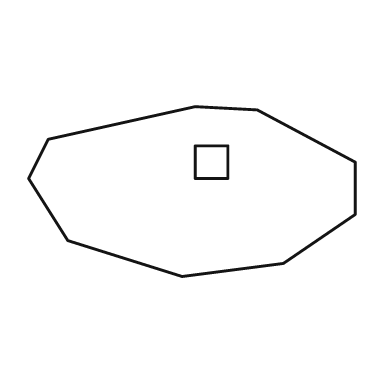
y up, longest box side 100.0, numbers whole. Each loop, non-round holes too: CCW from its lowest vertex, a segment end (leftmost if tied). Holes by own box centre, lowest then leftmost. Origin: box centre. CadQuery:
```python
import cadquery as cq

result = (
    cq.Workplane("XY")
    .moveTo(-3.0, -26.0)
    .lineTo(28.0, -22.0)
    .lineTo(50.0, -7.0)
    .lineTo(50.0, 9.0)
    .lineTo(20.0, 25.0)
    .lineTo(1.0, 26.0)
    .lineTo(-44.0, 16.0)
    .lineTo(-50.0, 4.0)
    .lineTo(-38.0, -15.0)
    .close()
    .moveTo(1.0, 4.0)
    .lineTo(11.0, 4.0)
    .lineTo(11.0, 14.0)
    .lineTo(1.0, 14.0)
    .close()
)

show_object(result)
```